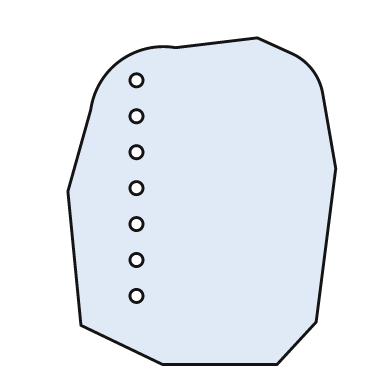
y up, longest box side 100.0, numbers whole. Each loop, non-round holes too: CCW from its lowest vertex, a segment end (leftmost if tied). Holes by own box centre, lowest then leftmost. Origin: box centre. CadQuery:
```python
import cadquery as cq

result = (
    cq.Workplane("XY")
    .moveTo(-12.0, -50.0)
    .lineTo(23.0, -50.0)
    .lineTo(35.0, -37.0)
    .lineTo(41.0, 10.0)
    .lineTo(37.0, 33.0)
    .threePointArc((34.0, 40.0), (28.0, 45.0))
    .lineTo(17.0, 50.0)
    .lineTo(-8.0, 47.0)
    .threePointArc((-25.0, 43.0), (-34.0, 28.0))
    .lineTo(-41.0, 3.0)
    .lineTo(-37.0, -38.0)
    .close()
    .moveTo(-20.0, -29.0)
    .circle(2.0)
    .moveTo(-20.0, -18.0)
    .circle(2.0)
    .moveTo(-20.0, -7.0)
    .circle(2.0)
    .moveTo(-20.0, 4.0)
    .circle(2.0)
    .moveTo(-20.0, 15.0)
    .circle(2.0)
    .moveTo(-20.0, 26.0)
    .circle(2.0)
    .moveTo(-20.0, 37.0)
    .circle(2.0)
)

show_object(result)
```